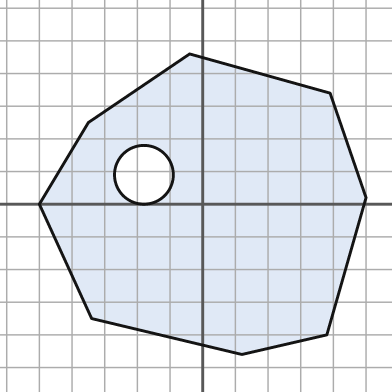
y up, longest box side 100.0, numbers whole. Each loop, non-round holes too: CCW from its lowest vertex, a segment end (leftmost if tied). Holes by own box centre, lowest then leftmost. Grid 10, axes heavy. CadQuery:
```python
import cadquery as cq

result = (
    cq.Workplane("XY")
    .moveTo(12.0, -46.0)
    .lineTo(38.0, -40.0)
    .lineTo(50.0, 2.0)
    .lineTo(39.0, 34.0)
    .lineTo(-4.0, 46.0)
    .lineTo(-35.0, 25.0)
    .lineTo(-50.0, 0.0)
    .lineTo(-34.0, -35.0)
    .close()
    .moveTo(-18.0, 9.0)
    .circle(9.0)
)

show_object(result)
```